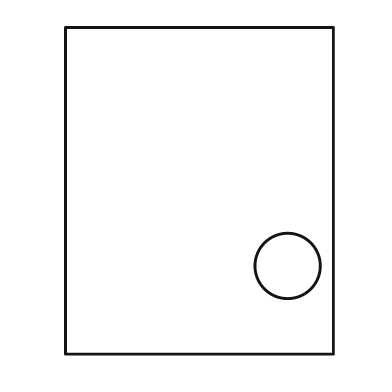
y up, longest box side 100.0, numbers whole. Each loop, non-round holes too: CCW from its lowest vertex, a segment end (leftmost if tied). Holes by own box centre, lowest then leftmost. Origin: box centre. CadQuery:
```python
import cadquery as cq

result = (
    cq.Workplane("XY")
    .moveTo(-41.0, -50.0)
    .lineTo(41.0, -50.0)
    .lineTo(41.0, 50.0)
    .lineTo(-41.0, 50.0)
    .close()
    .moveTo(27.0, -23.0)
    .circle(10.0)
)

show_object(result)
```